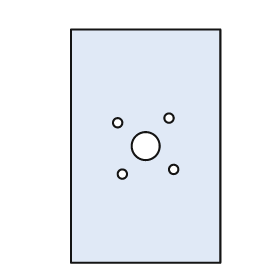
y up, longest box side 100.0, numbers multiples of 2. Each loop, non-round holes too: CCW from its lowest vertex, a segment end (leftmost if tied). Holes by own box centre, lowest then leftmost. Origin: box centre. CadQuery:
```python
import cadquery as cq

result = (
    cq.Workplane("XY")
    .moveTo(-32.0, -50.0)
    .lineTo(32.0, -50.0)
    .lineTo(32.0, 50.0)
    .lineTo(-32.0, 50.0)
    .close()
    .moveTo(-10.0, -12.0)
    .circle(2.0)
    .moveTo(12.0, -10.0)
    .circle(2.0)
    .moveTo(0.0, 0.0)
    .circle(6.0)
    .moveTo(-12.0, 10.0)
    .circle(2.0)
    .moveTo(10.0, 12.0)
    .circle(2.0)
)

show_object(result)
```